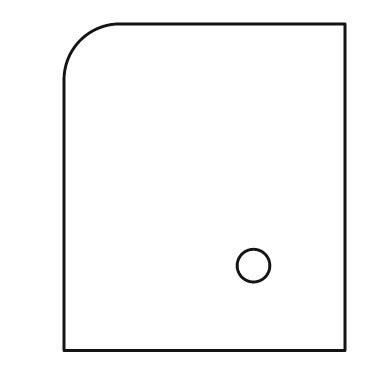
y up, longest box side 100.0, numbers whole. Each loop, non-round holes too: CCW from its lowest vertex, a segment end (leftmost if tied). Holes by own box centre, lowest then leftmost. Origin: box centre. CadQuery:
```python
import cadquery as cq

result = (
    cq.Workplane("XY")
    .moveTo(-43.0, -50.0)
    .lineTo(43.0, -50.0)
    .lineTo(43.0, 50.0)
    .lineTo(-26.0, 50.0)
    .threePointArc((-38.0, 45.0), (-43.0, 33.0))
    .close()
    .moveTo(15.0, -24.0)
    .circle(5.0)
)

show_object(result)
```